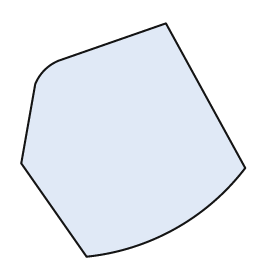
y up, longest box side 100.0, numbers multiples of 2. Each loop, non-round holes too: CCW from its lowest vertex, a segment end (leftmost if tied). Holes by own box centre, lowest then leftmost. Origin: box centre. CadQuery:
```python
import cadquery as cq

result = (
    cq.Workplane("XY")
    .moveTo(-20.0, -50.0)
    .threePointArc((18.0, -38.0), (48.0, -12.0))
    .lineTo(14.0, 50.0)
    .lineTo(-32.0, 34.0)
    .threePointArc((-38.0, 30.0), (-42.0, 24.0))
    .lineTo(-48.0, -10.0)
    .close()
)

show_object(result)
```